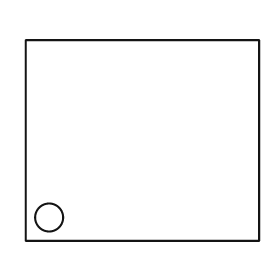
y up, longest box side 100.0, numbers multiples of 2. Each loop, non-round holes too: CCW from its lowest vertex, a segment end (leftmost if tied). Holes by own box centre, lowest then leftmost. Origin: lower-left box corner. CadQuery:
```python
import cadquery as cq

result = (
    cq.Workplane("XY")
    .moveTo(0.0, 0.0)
    .lineTo(100.0, 0.0)
    .lineTo(100.0, 86.0)
    .lineTo(0.0, 86.0)
    .close()
    .moveTo(10.0, 10.0)
    .circle(6.0)
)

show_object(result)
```